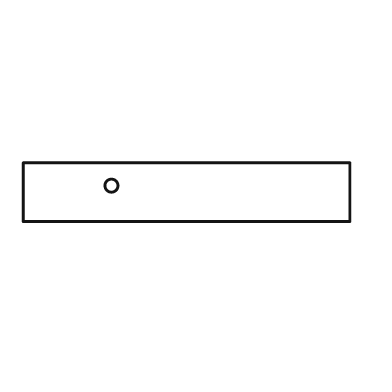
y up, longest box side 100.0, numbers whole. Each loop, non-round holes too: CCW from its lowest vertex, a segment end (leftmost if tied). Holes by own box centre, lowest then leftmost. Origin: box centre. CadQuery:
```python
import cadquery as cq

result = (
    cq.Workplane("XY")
    .moveTo(-50.0, -9.0)
    .lineTo(50.0, -9.0)
    .lineTo(50.0, 9.0)
    .lineTo(-50.0, 9.0)
    .close()
    .moveTo(-23.0, 2.0)
    .circle(2.0)
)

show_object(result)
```